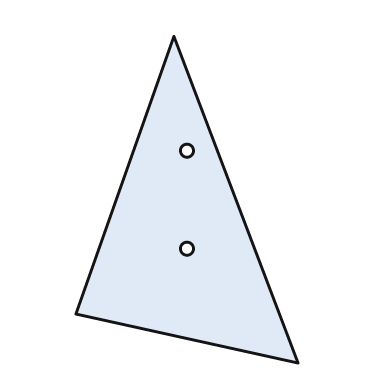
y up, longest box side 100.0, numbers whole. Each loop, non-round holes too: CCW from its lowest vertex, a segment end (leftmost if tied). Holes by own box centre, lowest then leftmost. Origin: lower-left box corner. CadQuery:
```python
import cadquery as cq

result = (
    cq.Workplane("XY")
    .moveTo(68.0, 0.0)
    .lineTo(30.0, 100.0)
    .lineTo(0.0, 15.0)
    .close()
    .moveTo(34.0, 35.0)
    .circle(2.0)
    .moveTo(34.0, 65.0)
    .circle(2.0)
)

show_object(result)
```